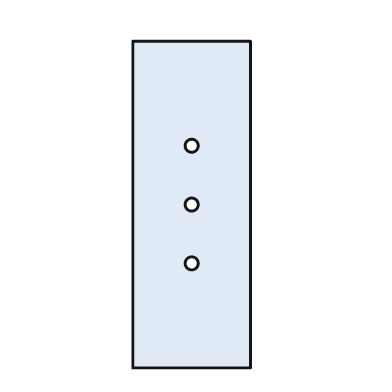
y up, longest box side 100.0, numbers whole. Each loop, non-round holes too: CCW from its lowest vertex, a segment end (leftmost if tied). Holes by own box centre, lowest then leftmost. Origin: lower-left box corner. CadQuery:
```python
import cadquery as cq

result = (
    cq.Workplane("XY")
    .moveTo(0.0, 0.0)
    .lineTo(36.0, 0.0)
    .lineTo(36.0, 100.0)
    .lineTo(0.0, 100.0)
    .close()
    .moveTo(18.0, 32.0)
    .circle(2.0)
    .moveTo(18.0, 50.0)
    .circle(2.0)
    .moveTo(18.0, 68.0)
    .circle(2.0)
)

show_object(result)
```